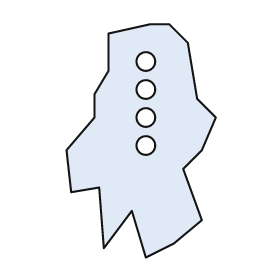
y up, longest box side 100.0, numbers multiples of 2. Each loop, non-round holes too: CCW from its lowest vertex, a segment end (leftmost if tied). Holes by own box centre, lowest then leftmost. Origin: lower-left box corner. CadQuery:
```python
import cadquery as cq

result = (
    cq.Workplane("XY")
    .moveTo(34.0, 0.0)
    .lineTo(46.0, 6.0)
    .lineTo(58.0, 16.0)
    .lineTo(50.0, 38.0)
    .lineTo(58.0, 46.0)
    .lineTo(64.0, 60.0)
    .lineTo(56.0, 68.0)
    .lineTo(52.0, 92.0)
    .lineTo(44.0, 100.0)
    .lineTo(36.0, 100.0)
    .lineTo(18.0, 96.0)
    .lineTo(18.0, 80.0)
    .lineTo(12.0, 70.0)
    .lineTo(12.0, 60.0)
    .lineTo(0.0, 46.0)
    .lineTo(2.0, 28.0)
    .lineTo(14.0, 30.0)
    .lineTo(16.0, 4.0)
    .lineTo(28.0, 20.0)
    .close()
    .moveTo(34.0, 48.0)
    .circle(4.0)
    .moveTo(34.0, 60.0)
    .circle(4.0)
    .moveTo(34.0, 72.0)
    .circle(4.0)
    .moveTo(34.0, 84.0)
    .circle(4.0)
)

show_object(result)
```